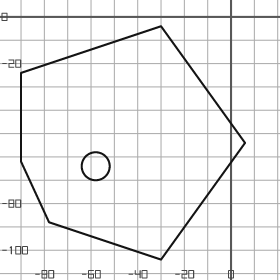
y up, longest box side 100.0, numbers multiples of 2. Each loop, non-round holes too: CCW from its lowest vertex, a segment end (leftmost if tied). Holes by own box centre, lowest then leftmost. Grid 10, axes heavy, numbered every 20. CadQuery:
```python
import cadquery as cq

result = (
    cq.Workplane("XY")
    .moveTo(-30.0, -104.0)
    .lineTo(6.0, -54.0)
    .lineTo(-30.0, -4.0)
    .lineTo(-90.0, -24.0)
    .lineTo(-90.0, -62.0)
    .lineTo(-78.0, -88.0)
    .close()
    .moveTo(-58.0, -64.0)
    .circle(6.0)
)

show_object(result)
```